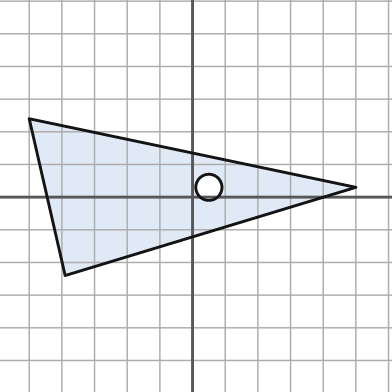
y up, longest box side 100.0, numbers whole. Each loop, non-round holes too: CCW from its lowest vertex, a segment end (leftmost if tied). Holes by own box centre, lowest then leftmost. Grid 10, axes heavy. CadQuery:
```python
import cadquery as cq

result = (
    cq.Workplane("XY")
    .moveTo(-39.0, -24.0)
    .lineTo(50.0, 3.0)
    .lineTo(-50.0, 24.0)
    .close()
    .moveTo(5.0, 3.0)
    .circle(4.0)
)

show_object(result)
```